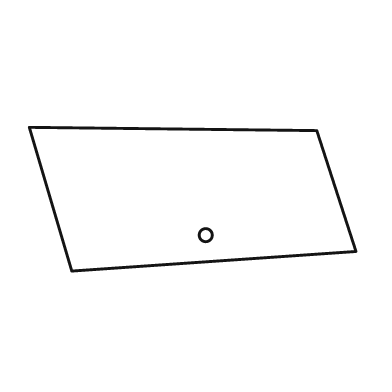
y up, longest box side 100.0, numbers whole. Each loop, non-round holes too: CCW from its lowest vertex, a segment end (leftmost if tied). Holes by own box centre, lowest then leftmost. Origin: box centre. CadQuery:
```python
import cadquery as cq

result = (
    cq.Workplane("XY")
    .moveTo(-37.0, -22.0)
    .lineTo(50.0, -16.0)
    .lineTo(38.0, 21.0)
    .lineTo(-50.0, 22.0)
    .close()
    .moveTo(4.0, -11.0)
    .circle(2.0)
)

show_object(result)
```